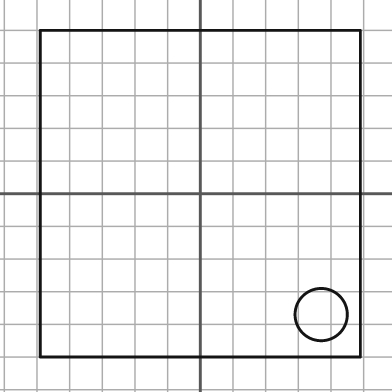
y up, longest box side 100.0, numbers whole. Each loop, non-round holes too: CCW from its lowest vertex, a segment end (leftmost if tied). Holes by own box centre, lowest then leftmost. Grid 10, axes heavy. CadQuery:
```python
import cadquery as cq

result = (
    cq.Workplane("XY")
    .moveTo(-49.0, -50.0)
    .lineTo(49.0, -50.0)
    .lineTo(49.0, 50.0)
    .lineTo(-49.0, 50.0)
    .close()
    .moveTo(37.0, -37.0)
    .circle(8.0)
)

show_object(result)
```